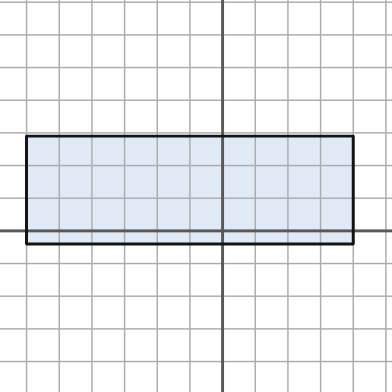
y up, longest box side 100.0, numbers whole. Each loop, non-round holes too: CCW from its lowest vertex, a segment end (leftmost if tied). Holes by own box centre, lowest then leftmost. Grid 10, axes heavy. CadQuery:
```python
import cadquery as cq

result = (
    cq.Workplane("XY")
    .moveTo(-60.0, -4.0)
    .lineTo(40.0, -4.0)
    .lineTo(40.0, 29.0)
    .lineTo(-60.0, 29.0)
    .close()
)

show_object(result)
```